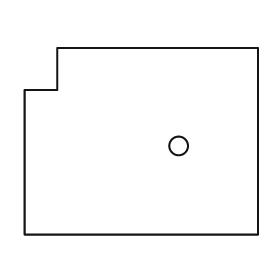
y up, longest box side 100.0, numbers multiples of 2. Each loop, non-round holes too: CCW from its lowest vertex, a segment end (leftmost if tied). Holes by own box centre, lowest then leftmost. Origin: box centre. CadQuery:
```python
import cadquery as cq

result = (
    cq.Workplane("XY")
    .moveTo(-50.0, -40.0)
    .lineTo(50.0, -40.0)
    .lineTo(50.0, 40.0)
    .lineTo(-36.0, 40.0)
    .lineTo(-36.0, 22.0)
    .lineTo(-50.0, 22.0)
    .close()
    .moveTo(16.0, -2.0)
    .circle(4.0)
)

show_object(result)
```